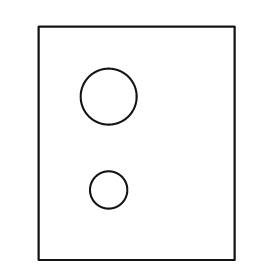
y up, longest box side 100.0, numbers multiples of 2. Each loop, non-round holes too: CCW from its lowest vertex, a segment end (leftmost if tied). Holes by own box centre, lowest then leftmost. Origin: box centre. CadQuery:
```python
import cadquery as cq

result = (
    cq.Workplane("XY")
    .moveTo(-42.0, -50.0)
    .lineTo(42.0, -50.0)
    .lineTo(42.0, 50.0)
    .lineTo(-42.0, 50.0)
    .close()
    .moveTo(-12.0, -20.0)
    .circle(8.0)
    .moveTo(-12.0, 20.0)
    .circle(12.0)
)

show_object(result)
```